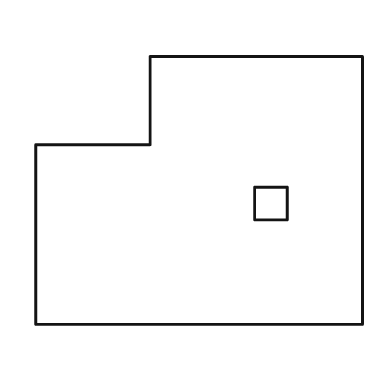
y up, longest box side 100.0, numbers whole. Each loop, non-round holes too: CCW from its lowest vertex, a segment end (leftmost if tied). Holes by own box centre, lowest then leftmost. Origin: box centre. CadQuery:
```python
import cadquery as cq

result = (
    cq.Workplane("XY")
    .moveTo(-50.0, -41.0)
    .lineTo(50.0, -41.0)
    .lineTo(50.0, 41.0)
    .lineTo(-15.0, 41.0)
    .lineTo(-15.0, 14.0)
    .lineTo(-50.0, 14.0)
    .close()
    .moveTo(17.0, -9.0)
    .lineTo(27.0, -9.0)
    .lineTo(27.0, 1.0)
    .lineTo(17.0, 1.0)
    .close()
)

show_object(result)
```